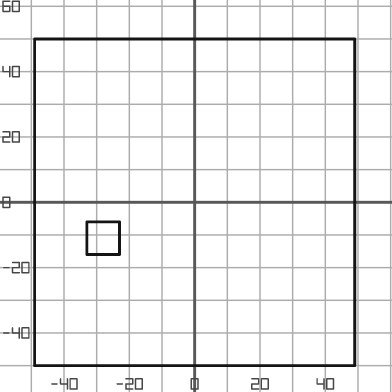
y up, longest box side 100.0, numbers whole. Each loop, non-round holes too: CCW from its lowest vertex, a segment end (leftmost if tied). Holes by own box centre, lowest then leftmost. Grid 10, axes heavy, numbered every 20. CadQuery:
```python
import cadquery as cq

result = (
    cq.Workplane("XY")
    .moveTo(-49.0, -50.0)
    .lineTo(49.0, -50.0)
    .lineTo(49.0, 50.0)
    .lineTo(-49.0, 50.0)
    .close()
    .moveTo(-33.0, -16.0)
    .lineTo(-23.0, -16.0)
    .lineTo(-23.0, -6.0)
    .lineTo(-33.0, -6.0)
    .close()
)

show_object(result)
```